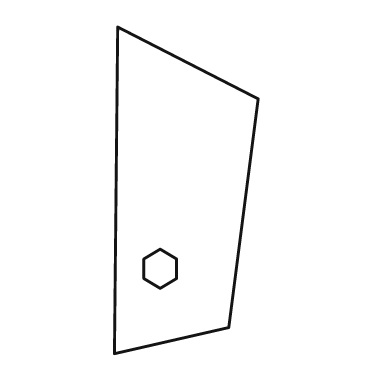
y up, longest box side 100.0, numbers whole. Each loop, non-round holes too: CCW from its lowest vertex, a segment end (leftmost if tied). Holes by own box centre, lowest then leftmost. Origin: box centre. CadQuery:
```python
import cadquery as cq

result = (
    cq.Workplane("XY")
    .moveTo(-22.0, -50.0)
    .lineTo(13.0, -42.0)
    .lineTo(22.0, 28.0)
    .lineTo(-21.0, 50.0)
    .close()
    .moveTo(-8.0, -30.0)
    .lineTo(-3.0, -27.0)
    .lineTo(-3.0, -21.0)
    .lineTo(-8.0, -18.0)
    .lineTo(-13.0, -21.0)
    .lineTo(-13.0, -27.0)
    .close()
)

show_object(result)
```